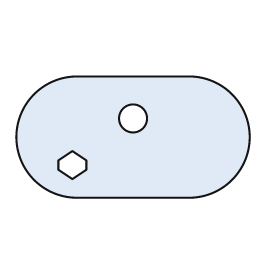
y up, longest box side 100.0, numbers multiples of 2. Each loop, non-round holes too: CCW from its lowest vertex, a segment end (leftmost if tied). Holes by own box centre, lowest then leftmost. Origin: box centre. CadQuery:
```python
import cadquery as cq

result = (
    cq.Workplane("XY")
    .moveTo(-24.0, -26.0)
    .lineTo(24.0, -26.0)
    .threePointArc((50.0, 0.0), (24.0, 26.0))
    .lineTo(-24.0, 26.0)
    .threePointArc((-50.0, 0.0), (-24.0, -26.0))
    .close()
    .moveTo(-26.0, -18.0)
    .lineTo(-20.0, -14.0)
    .lineTo(-20.0, -10.0)
    .lineTo(-26.0, -6.0)
    .lineTo(-32.0, -10.0)
    .lineTo(-32.0, -14.0)
    .close()
    .moveTo(0.0, 8.0)
    .circle(6.0)
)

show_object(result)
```